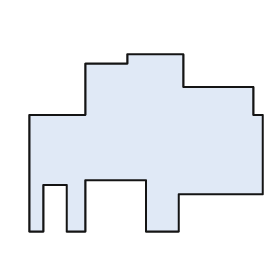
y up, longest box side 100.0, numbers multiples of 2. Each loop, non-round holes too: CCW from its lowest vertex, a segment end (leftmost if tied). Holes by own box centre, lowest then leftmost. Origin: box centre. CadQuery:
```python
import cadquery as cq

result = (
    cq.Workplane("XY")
    .moveTo(-50.0, -38.0)
    .lineTo(-44.0, -38.0)
    .lineTo(-44.0, -18.0)
    .lineTo(-34.0, -18.0)
    .lineTo(-34.0, -38.0)
    .lineTo(-26.0, -38.0)
    .lineTo(-26.0, -16.0)
    .lineTo(0.0, -16.0)
    .lineTo(0.0, -38.0)
    .lineTo(14.0, -38.0)
    .lineTo(14.0, -22.0)
    .lineTo(50.0, -22.0)
    .lineTo(50.0, 12.0)
    .lineTo(46.0, 12.0)
    .lineTo(46.0, 24.0)
    .lineTo(16.0, 24.0)
    .lineTo(16.0, 38.0)
    .lineTo(-8.0, 38.0)
    .lineTo(-8.0, 34.0)
    .lineTo(-26.0, 34.0)
    .lineTo(-26.0, 12.0)
    .lineTo(-50.0, 12.0)
    .close()
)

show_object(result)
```